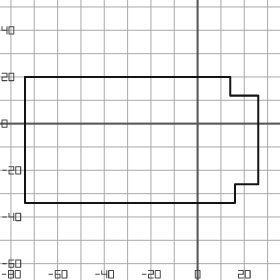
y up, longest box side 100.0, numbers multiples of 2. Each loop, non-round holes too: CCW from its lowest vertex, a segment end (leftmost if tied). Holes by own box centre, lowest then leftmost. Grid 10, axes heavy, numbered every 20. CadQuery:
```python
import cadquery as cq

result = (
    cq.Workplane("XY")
    .moveTo(-74.0, -34.0)
    .lineTo(16.0, -34.0)
    .lineTo(16.0, -26.0)
    .lineTo(26.0, -26.0)
    .lineTo(26.0, 12.0)
    .lineTo(14.0, 12.0)
    .lineTo(14.0, 20.0)
    .lineTo(-74.0, 20.0)
    .close()
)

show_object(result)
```